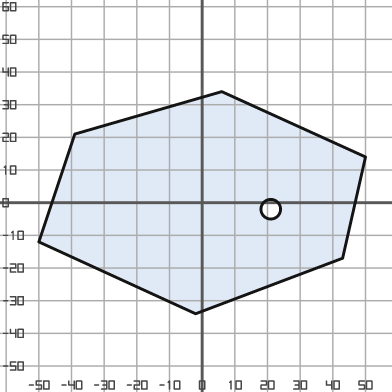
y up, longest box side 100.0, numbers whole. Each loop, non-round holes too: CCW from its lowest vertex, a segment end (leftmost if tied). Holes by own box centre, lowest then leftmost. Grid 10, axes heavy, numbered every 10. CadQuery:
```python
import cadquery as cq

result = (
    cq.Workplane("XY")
    .moveTo(-2.0, -34.0)
    .lineTo(43.0, -17.0)
    .lineTo(50.0, 14.0)
    .lineTo(6.0, 34.0)
    .lineTo(-39.0, 21.0)
    .lineTo(-50.0, -12.0)
    .close()
    .moveTo(21.0, -2.0)
    .circle(3.0)
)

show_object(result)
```